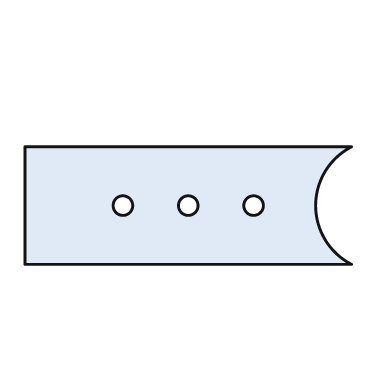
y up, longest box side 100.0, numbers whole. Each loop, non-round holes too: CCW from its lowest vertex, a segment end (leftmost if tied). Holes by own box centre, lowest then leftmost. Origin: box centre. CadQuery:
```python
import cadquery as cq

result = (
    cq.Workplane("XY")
    .moveTo(-50.0, -18.0)
    .lineTo(50.0, -18.0)
    .threePointArc((39.0, 0.0), (50.0, 18.0))
    .lineTo(-50.0, 18.0)
    .close()
    .moveTo(-20.0, 0.0)
    .circle(3.0)
    .moveTo(0.0, 0.0)
    .circle(3.0)
    .moveTo(20.0, 0.0)
    .circle(3.0)
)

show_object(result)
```